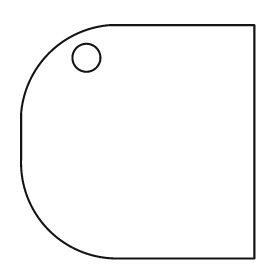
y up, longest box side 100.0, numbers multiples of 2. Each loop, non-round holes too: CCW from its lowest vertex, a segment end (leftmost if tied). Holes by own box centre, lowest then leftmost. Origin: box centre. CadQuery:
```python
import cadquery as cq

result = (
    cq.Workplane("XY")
    .moveTo(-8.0, -50.0)
    .lineTo(50.0, -50.0)
    .lineTo(50.0, 50.0)
    .lineTo(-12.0, 50.0)
    .threePointArc((-38.0, 38.0), (-50.0, 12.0))
    .lineTo(-50.0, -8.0)
    .threePointArc((-38.0, -38.0), (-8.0, -50.0))
    .close()
    .moveTo(-22.0, 36.0)
    .circle(6.0)
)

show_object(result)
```